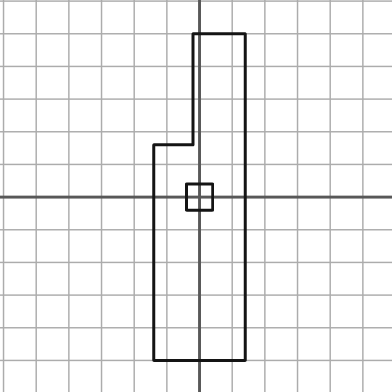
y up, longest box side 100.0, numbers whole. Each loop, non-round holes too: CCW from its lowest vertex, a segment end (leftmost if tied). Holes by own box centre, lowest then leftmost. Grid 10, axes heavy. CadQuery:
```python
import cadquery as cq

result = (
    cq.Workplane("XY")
    .moveTo(-14.0, -50.0)
    .lineTo(14.0, -50.0)
    .lineTo(14.0, 50.0)
    .lineTo(-2.0, 50.0)
    .lineTo(-2.0, 16.0)
    .lineTo(-14.0, 16.0)
    .close()
    .moveTo(-4.0, -4.0)
    .lineTo(4.0, -4.0)
    .lineTo(4.0, 4.0)
    .lineTo(-4.0, 4.0)
    .close()
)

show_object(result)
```